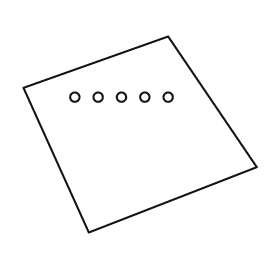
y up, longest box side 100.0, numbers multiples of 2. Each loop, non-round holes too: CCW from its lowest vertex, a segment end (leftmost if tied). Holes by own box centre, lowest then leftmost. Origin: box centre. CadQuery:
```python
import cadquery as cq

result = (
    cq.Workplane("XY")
    .moveTo(-22.0, -42.0)
    .lineTo(50.0, -14.0)
    .lineTo(12.0, 42.0)
    .lineTo(-50.0, 20.0)
    .close()
    .moveTo(-28.0, 16.0)
    .circle(2.0)
    .moveTo(-18.0, 16.0)
    .circle(2.0)
    .moveTo(-8.0, 16.0)
    .circle(2.0)
    .moveTo(2.0, 16.0)
    .circle(2.0)
    .moveTo(12.0, 16.0)
    .circle(2.0)
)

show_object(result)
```